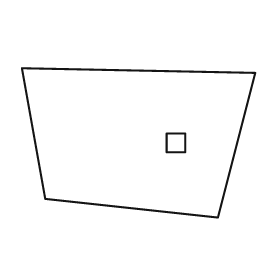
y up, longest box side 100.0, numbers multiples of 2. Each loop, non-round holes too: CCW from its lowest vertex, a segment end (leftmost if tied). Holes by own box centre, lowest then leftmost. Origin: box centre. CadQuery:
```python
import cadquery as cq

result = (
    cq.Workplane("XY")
    .moveTo(34.0, -32.0)
    .lineTo(50.0, 30.0)
    .lineTo(-50.0, 32.0)
    .lineTo(-40.0, -24.0)
    .close()
    .moveTo(12.0, -4.0)
    .lineTo(20.0, -4.0)
    .lineTo(20.0, 4.0)
    .lineTo(12.0, 4.0)
    .close()
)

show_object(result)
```